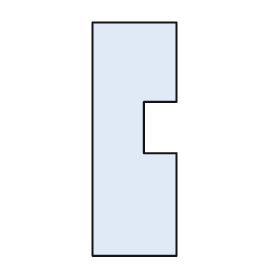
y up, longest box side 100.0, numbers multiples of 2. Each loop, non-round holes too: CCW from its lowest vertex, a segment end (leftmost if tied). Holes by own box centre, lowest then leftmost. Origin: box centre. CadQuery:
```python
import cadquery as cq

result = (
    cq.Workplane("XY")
    .moveTo(-18.0, -50.0)
    .lineTo(18.0, -50.0)
    .lineTo(18.0, -6.0)
    .lineTo(4.0, -6.0)
    .lineTo(4.0, 16.0)
    .lineTo(18.0, 16.0)
    .lineTo(18.0, 50.0)
    .lineTo(-18.0, 50.0)
    .close()
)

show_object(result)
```